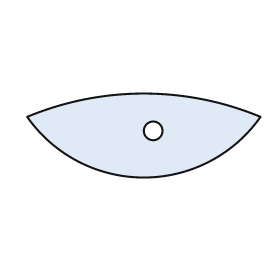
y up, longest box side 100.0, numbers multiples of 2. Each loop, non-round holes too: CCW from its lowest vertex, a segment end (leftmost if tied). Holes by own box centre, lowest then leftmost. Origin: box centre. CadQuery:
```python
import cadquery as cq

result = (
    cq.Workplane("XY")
    .moveTo(-50.0, 8.0)
    .threePointArc((0.0, -18.0), (50.0, 8.0))
    .threePointArc((0.0, 18.0), (-50.0, 8.0))
    .close()
    .moveTo(4.0, 2.0)
    .circle(4.0)
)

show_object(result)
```